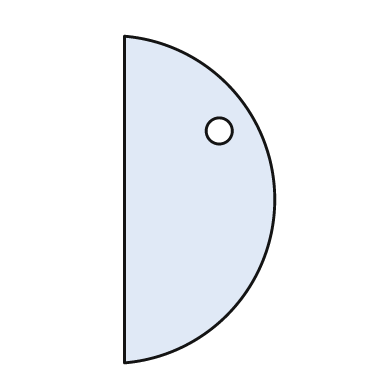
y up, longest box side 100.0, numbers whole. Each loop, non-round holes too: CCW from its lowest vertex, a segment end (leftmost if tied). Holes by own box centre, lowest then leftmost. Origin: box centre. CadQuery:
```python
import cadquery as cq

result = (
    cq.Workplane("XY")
    .moveTo(-23.0, -50.0)
    .threePointArc((23.0, 0.0), (-23.0, 50.0))
    .close()
    .moveTo(6.0, 21.0)
    .circle(4.0)
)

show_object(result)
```